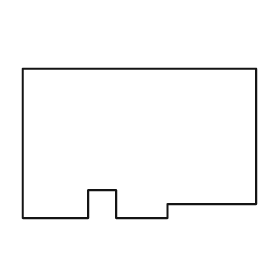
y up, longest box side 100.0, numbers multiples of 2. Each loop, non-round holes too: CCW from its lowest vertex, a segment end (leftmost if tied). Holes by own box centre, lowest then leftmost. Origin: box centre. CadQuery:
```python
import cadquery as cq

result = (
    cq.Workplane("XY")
    .moveTo(-50.0, -32.0)
    .lineTo(-22.0, -32.0)
    .lineTo(-22.0, -20.0)
    .lineTo(-10.0, -20.0)
    .lineTo(-10.0, -32.0)
    .lineTo(12.0, -32.0)
    .lineTo(12.0, -26.0)
    .lineTo(50.0, -26.0)
    .lineTo(50.0, 32.0)
    .lineTo(-50.0, 32.0)
    .close()
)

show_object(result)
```